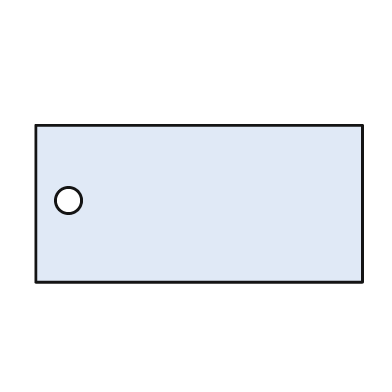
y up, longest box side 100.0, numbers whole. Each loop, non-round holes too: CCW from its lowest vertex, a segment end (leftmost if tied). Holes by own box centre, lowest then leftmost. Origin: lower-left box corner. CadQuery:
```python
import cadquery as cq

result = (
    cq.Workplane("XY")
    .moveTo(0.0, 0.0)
    .lineTo(100.0, 0.0)
    .lineTo(100.0, 48.0)
    .lineTo(0.0, 48.0)
    .close()
    .moveTo(10.0, 25.0)
    .circle(4.0)
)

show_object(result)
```